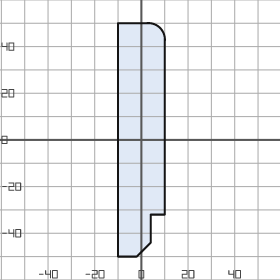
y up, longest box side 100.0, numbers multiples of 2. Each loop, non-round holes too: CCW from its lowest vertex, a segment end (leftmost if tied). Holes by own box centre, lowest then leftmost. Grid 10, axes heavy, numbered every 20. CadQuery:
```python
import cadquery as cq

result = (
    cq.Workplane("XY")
    .moveTo(-10.0, -50.0)
    .lineTo(-2.0, -50.0)
    .lineTo(4.0, -44.0)
    .lineTo(4.0, -32.0)
    .lineTo(10.0, -32.0)
    .lineTo(10.0, 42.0)
    .threePointArc((8.0, 48.0), (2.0, 50.0))
    .lineTo(-10.0, 50.0)
    .close()
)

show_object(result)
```